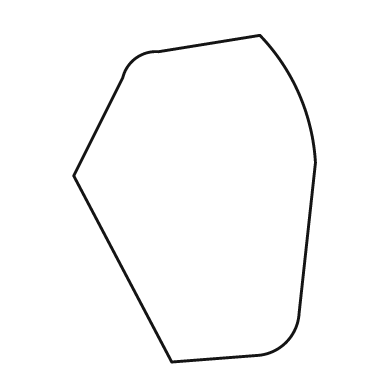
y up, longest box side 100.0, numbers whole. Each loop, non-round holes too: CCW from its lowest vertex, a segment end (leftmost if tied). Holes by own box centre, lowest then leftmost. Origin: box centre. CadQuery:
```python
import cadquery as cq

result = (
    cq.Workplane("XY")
    .moveTo(-7.0, -50.0)
    .lineTo(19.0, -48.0)
    .threePointArc((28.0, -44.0), (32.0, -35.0))
    .lineTo(37.0, 11.0)
    .threePointArc((32.0, 32.0), (20.0, 50.0))
    .lineTo(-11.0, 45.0)
    .threePointArc((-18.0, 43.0), (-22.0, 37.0))
    .lineTo(-37.0, 7.0)
    .close()
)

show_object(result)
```